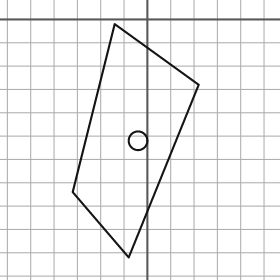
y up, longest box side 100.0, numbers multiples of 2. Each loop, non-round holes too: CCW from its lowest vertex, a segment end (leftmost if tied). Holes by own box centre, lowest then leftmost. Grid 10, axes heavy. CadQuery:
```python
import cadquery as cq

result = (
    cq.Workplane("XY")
    .moveTo(-8.0, -102.0)
    .lineTo(22.0, -28.0)
    .lineTo(-14.0, -2.0)
    .lineTo(-32.0, -74.0)
    .close()
    .moveTo(-4.0, -52.0)
    .circle(4.0)
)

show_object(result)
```